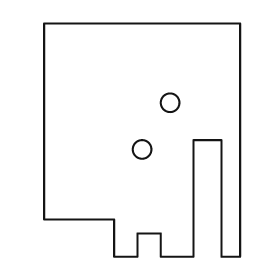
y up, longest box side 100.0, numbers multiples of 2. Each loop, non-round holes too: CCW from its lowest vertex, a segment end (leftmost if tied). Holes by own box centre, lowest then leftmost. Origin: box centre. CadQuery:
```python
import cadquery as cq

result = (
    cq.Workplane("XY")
    .moveTo(-12.0, -50.0)
    .lineTo(-2.0, -50.0)
    .lineTo(-2.0, -40.0)
    .lineTo(8.0, -40.0)
    .lineTo(8.0, -50.0)
    .lineTo(22.0, -50.0)
    .lineTo(22.0, 0.0)
    .lineTo(34.0, 0.0)
    .lineTo(34.0, -50.0)
    .lineTo(42.0, -50.0)
    .lineTo(42.0, 50.0)
    .lineTo(-42.0, 50.0)
    .lineTo(-42.0, -34.0)
    .lineTo(-12.0, -34.0)
    .close()
    .moveTo(0.0, -4.0)
    .circle(4.0)
    .moveTo(12.0, 16.0)
    .circle(4.0)
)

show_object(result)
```